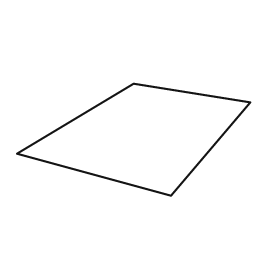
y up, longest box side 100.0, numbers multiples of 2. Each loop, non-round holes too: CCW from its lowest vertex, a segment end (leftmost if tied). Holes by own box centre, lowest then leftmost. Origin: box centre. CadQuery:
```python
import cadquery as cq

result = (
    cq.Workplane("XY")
    .moveTo(16.0, -24.0)
    .lineTo(50.0, 16.0)
    .lineTo(0.0, 24.0)
    .lineTo(-50.0, -6.0)
    .close()
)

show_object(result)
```